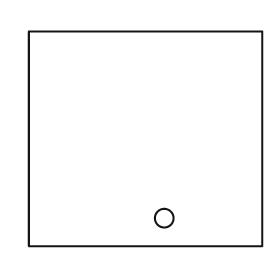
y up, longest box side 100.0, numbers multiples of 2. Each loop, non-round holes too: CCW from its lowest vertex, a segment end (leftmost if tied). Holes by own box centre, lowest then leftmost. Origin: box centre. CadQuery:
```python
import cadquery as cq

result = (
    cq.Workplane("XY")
    .moveTo(-50.0, -46.0)
    .lineTo(50.0, -46.0)
    .lineTo(50.0, 46.0)
    .lineTo(-50.0, 46.0)
    .close()
    .moveTo(8.0, -34.0)
    .circle(4.0)
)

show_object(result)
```